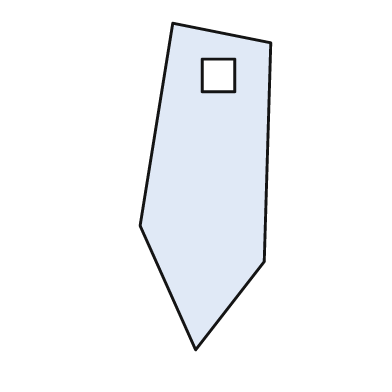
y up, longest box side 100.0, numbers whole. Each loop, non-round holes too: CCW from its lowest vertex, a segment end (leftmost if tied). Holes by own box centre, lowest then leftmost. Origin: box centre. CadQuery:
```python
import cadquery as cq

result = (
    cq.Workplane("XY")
    .moveTo(-3.0, -50.0)
    .lineTo(18.0, -23.0)
    .lineTo(20.0, 44.0)
    .lineTo(-10.0, 50.0)
    .lineTo(-20.0, -12.0)
    .close()
    .moveTo(-1.0, 29.0)
    .lineTo(9.0, 29.0)
    .lineTo(9.0, 39.0)
    .lineTo(-1.0, 39.0)
    .close()
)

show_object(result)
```